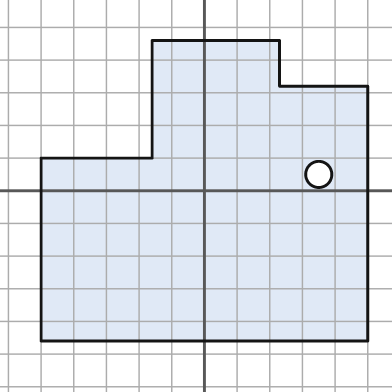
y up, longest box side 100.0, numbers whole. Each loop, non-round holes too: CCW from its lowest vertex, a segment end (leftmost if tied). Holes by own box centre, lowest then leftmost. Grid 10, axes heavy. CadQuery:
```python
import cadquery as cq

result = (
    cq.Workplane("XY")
    .moveTo(-50.0, -46.0)
    .lineTo(50.0, -46.0)
    .lineTo(50.0, 32.0)
    .lineTo(23.0, 32.0)
    .lineTo(23.0, 46.0)
    .lineTo(-16.0, 46.0)
    .lineTo(-16.0, 10.0)
    .lineTo(-50.0, 10.0)
    .close()
    .moveTo(35.0, 5.0)
    .circle(4.0)
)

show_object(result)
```